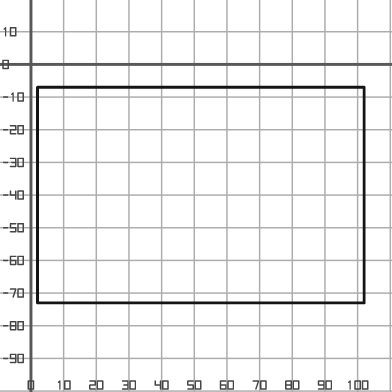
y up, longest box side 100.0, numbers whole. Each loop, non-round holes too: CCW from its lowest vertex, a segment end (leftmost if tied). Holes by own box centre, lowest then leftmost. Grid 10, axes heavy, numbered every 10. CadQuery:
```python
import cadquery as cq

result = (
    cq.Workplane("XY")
    .moveTo(2.0, -73.0)
    .lineTo(102.0, -73.0)
    .lineTo(102.0, -7.0)
    .lineTo(2.0, -7.0)
    .close()
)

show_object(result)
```